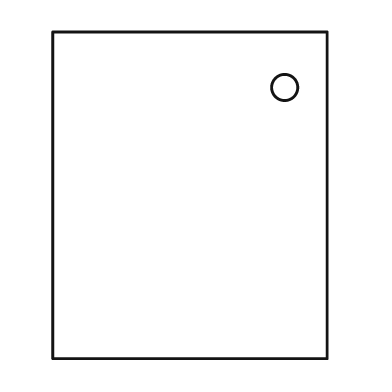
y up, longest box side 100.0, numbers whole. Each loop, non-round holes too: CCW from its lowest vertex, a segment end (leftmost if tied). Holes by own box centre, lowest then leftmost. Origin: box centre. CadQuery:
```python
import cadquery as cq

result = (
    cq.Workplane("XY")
    .moveTo(-42.0, -50.0)
    .lineTo(42.0, -50.0)
    .lineTo(42.0, 50.0)
    .lineTo(-42.0, 50.0)
    .close()
    .moveTo(29.0, 33.0)
    .circle(4.0)
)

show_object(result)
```